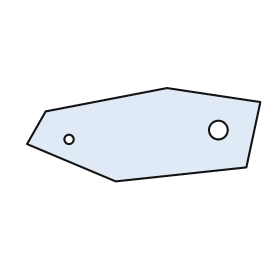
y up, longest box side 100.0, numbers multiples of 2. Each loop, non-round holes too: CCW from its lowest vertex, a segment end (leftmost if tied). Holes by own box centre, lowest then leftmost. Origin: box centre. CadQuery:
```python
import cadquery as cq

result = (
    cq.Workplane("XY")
    .moveTo(-12.0, -20.0)
    .lineTo(44.0, -14.0)
    .lineTo(50.0, 14.0)
    .lineTo(10.0, 20.0)
    .lineTo(-42.0, 10.0)
    .lineTo(-50.0, -4.0)
    .close()
    .moveTo(-32.0, -2.0)
    .circle(2.0)
    .moveTo(32.0, 2.0)
    .circle(4.0)
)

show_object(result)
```